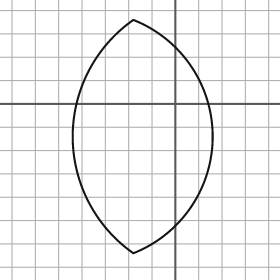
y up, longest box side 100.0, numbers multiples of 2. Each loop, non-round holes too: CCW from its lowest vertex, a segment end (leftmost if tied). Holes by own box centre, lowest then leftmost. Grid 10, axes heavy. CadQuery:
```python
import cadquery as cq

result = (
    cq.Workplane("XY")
    .moveTo(-18.0, -64.0)
    .threePointArc((16.0, -14.0), (-18.0, 36.0))
    .threePointArc((-44.0, -14.0), (-18.0, -64.0))
    .close()
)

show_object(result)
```